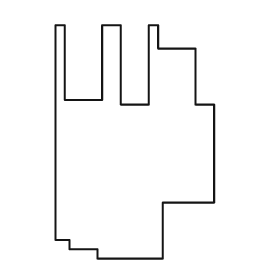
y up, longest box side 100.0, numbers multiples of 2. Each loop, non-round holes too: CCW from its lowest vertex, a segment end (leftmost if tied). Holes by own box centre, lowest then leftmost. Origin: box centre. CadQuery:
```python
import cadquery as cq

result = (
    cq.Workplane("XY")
    .moveTo(-16.0, -50.0)
    .lineTo(12.0, -50.0)
    .lineTo(12.0, -26.0)
    .lineTo(34.0, -26.0)
    .lineTo(34.0, 16.0)
    .lineTo(26.0, 16.0)
    .lineTo(26.0, 40.0)
    .lineTo(10.0, 40.0)
    .lineTo(10.0, 50.0)
    .lineTo(6.0, 50.0)
    .lineTo(6.0, 16.0)
    .lineTo(-6.0, 16.0)
    .lineTo(-6.0, 50.0)
    .lineTo(-14.0, 50.0)
    .lineTo(-14.0, 18.0)
    .lineTo(-30.0, 18.0)
    .lineTo(-30.0, 50.0)
    .lineTo(-34.0, 50.0)
    .lineTo(-34.0, -42.0)
    .lineTo(-28.0, -42.0)
    .lineTo(-28.0, -46.0)
    .lineTo(-16.0, -46.0)
    .close()
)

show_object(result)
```